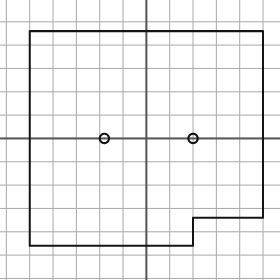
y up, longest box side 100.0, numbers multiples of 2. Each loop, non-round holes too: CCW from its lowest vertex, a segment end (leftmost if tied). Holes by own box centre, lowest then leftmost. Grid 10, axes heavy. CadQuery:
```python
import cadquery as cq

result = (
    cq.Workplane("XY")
    .moveTo(-50.0, -46.0)
    .lineTo(20.0, -46.0)
    .lineTo(20.0, -34.0)
    .lineTo(50.0, -34.0)
    .lineTo(50.0, 46.0)
    .lineTo(-50.0, 46.0)
    .close()
    .moveTo(-18.0, 0.0)
    .circle(2.0)
    .moveTo(20.0, 0.0)
    .circle(2.0)
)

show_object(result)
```